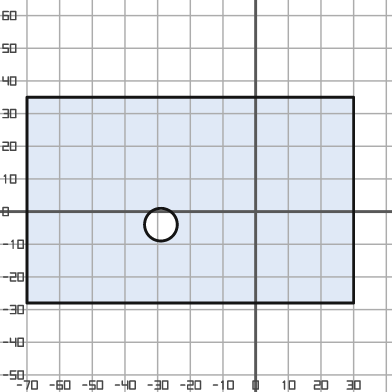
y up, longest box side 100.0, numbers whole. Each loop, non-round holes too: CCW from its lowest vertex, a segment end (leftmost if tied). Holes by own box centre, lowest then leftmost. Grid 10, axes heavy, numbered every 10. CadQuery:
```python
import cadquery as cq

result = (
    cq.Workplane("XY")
    .moveTo(-70.0, -28.0)
    .lineTo(30.0, -28.0)
    .lineTo(30.0, 35.0)
    .lineTo(-70.0, 35.0)
    .close()
    .moveTo(-29.0, -4.0)
    .circle(5.0)
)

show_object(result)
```